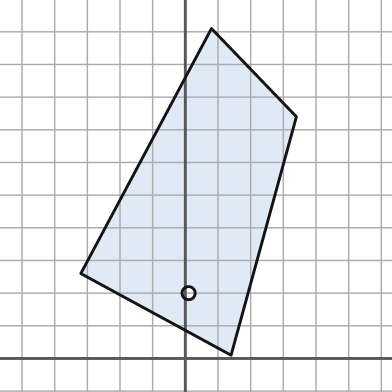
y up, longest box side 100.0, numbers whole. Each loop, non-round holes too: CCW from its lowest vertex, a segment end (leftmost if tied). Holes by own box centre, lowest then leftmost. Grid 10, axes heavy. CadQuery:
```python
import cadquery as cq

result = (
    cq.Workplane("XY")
    .moveTo(14.0, 1.0)
    .lineTo(34.0, 74.0)
    .lineTo(8.0, 101.0)
    .lineTo(-32.0, 26.0)
    .close()
    .moveTo(1.0, 20.0)
    .circle(2.0)
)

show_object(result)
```